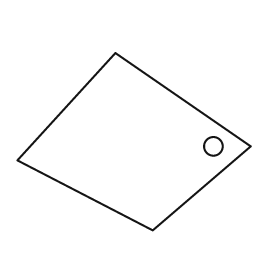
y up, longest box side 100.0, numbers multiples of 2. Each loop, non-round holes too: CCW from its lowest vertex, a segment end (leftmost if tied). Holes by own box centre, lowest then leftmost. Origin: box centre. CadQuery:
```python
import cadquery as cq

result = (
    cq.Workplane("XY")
    .moveTo(8.0, -38.0)
    .lineTo(50.0, -2.0)
    .lineTo(-8.0, 38.0)
    .lineTo(-50.0, -8.0)
    .close()
    .moveTo(34.0, -2.0)
    .circle(4.0)
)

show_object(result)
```